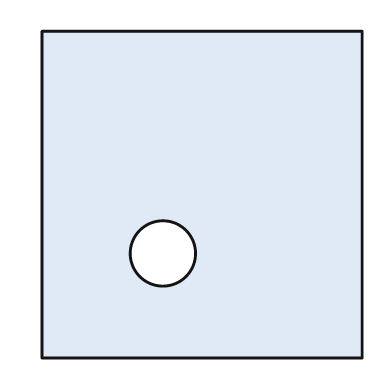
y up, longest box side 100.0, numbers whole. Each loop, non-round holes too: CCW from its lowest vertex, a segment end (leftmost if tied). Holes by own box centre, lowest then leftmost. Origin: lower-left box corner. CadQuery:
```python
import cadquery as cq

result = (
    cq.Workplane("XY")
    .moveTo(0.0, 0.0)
    .lineTo(98.0, 0.0)
    .lineTo(98.0, 100.0)
    .lineTo(0.0, 100.0)
    .close()
    .moveTo(37.0, 32.0)
    .circle(10.0)
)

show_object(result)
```